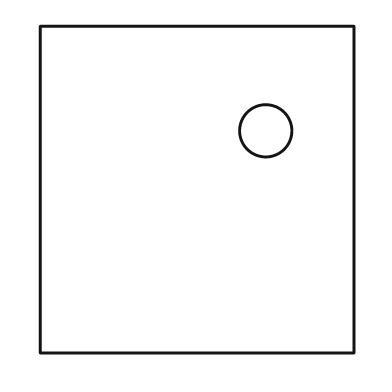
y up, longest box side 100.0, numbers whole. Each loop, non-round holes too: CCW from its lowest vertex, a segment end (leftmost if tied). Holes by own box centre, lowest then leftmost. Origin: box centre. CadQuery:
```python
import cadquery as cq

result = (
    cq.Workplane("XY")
    .moveTo(-48.0, -50.0)
    .lineTo(48.0, -50.0)
    .lineTo(48.0, 50.0)
    .lineTo(-48.0, 50.0)
    .close()
    .moveTo(21.0, 18.0)
    .circle(8.0)
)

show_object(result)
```